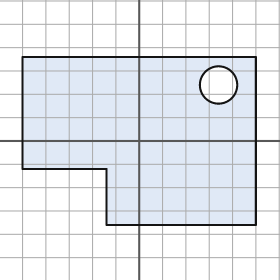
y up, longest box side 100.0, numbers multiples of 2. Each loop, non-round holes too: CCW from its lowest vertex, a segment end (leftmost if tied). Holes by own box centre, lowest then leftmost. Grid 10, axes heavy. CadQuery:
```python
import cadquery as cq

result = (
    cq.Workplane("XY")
    .moveTo(-14.0, -36.0)
    .lineTo(50.0, -36.0)
    .lineTo(50.0, 36.0)
    .lineTo(-50.0, 36.0)
    .lineTo(-50.0, -12.0)
    .lineTo(-14.0, -12.0)
    .close()
    .moveTo(34.0, 24.0)
    .circle(8.0)
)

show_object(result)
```